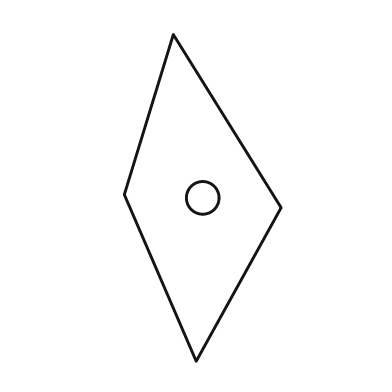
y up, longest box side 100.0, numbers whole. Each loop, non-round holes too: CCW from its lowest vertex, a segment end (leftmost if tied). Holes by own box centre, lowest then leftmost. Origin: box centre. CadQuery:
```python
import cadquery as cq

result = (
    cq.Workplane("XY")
    .moveTo(-2.0, -50.0)
    .lineTo(24.0, -3.0)
    .lineTo(-9.0, 50.0)
    .lineTo(-24.0, 1.0)
    .close()
    .moveTo(0.0, 0.0)
    .circle(5.0)
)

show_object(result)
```